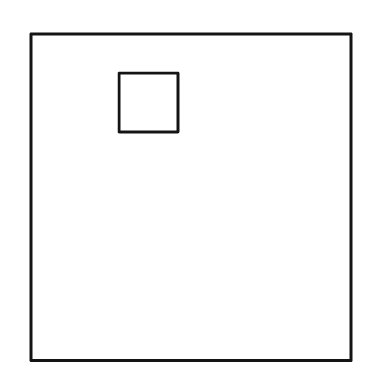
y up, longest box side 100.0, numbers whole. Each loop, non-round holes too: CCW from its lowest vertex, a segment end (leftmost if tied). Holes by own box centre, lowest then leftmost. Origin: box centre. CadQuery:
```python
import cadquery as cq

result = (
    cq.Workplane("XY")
    .moveTo(-49.0, -50.0)
    .lineTo(49.0, -50.0)
    .lineTo(49.0, 50.0)
    .lineTo(-49.0, 50.0)
    .close()
    .moveTo(-22.0, 20.0)
    .lineTo(-4.0, 20.0)
    .lineTo(-4.0, 38.0)
    .lineTo(-22.0, 38.0)
    .close()
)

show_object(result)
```